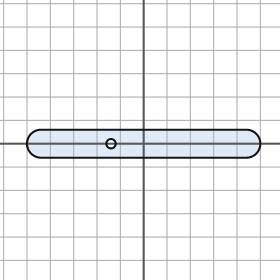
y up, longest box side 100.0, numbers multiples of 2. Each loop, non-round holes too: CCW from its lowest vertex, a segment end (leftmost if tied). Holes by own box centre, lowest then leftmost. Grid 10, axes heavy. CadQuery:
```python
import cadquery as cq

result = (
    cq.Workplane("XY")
    .moveTo(-44.0, -6.0)
    .lineTo(44.0, -6.0)
    .threePointArc((50.0, 0.0), (44.0, 6.0))
    .lineTo(-44.0, 6.0)
    .threePointArc((-50.0, 0.0), (-44.0, -6.0))
    .close()
    .moveTo(-14.0, 0.0)
    .circle(2.0)
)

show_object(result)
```